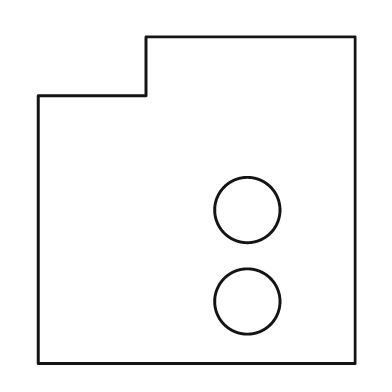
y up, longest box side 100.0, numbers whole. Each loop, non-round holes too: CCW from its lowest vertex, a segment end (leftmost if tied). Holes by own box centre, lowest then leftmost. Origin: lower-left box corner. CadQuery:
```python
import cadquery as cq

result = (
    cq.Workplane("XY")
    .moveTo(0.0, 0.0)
    .lineTo(97.0, 0.0)
    .lineTo(97.0, 100.0)
    .lineTo(33.0, 100.0)
    .lineTo(33.0, 82.0)
    .lineTo(0.0, 82.0)
    .close()
    .moveTo(64.0, 19.0)
    .circle(10.0)
    .moveTo(64.0, 47.0)
    .circle(10.0)
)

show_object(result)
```